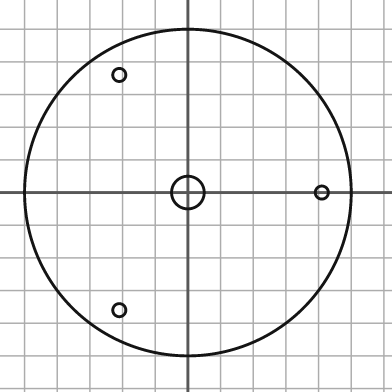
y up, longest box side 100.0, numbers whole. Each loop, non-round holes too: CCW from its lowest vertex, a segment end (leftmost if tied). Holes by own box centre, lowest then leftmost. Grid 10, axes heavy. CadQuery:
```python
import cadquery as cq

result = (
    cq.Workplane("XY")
    .moveTo(0.0, 0.0)
    .circle(50.0)
    .moveTo(-21.0, -36.0)
    .circle(2.0)
    .moveTo(0.0, 0.0)
    .circle(5.0)
    .moveTo(41.0, 0.0)
    .circle(2.0)
    .moveTo(-21.0, 36.0)
    .circle(2.0)
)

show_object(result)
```